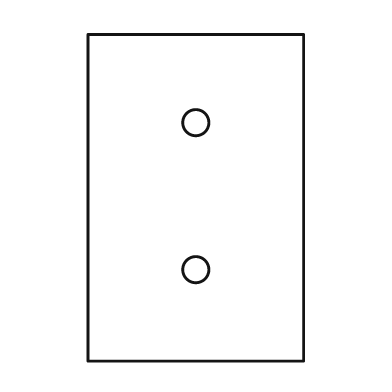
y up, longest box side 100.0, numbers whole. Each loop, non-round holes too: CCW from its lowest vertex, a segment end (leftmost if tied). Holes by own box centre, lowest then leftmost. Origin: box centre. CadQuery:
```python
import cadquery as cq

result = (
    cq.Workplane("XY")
    .moveTo(-33.0, -50.0)
    .lineTo(33.0, -50.0)
    .lineTo(33.0, 50.0)
    .lineTo(-33.0, 50.0)
    .close()
    .moveTo(0.0, -22.0)
    .circle(4.0)
    .moveTo(0.0, 23.0)
    .circle(4.0)
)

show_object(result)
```